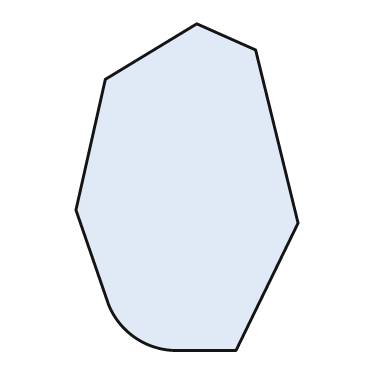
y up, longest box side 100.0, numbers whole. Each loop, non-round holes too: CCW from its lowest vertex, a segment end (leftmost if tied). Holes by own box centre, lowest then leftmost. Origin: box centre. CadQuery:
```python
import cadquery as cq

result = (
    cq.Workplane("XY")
    .moveTo(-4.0, -50.0)
    .lineTo(15.0, -50.0)
    .lineTo(34.0, -11.0)
    .lineTo(21.0, 42.0)
    .lineTo(3.0, 50.0)
    .lineTo(-25.0, 33.0)
    .lineTo(-34.0, -7.0)
    .lineTo(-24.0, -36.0)
    .threePointArc((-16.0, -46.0), (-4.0, -50.0))
    .close()
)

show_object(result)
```